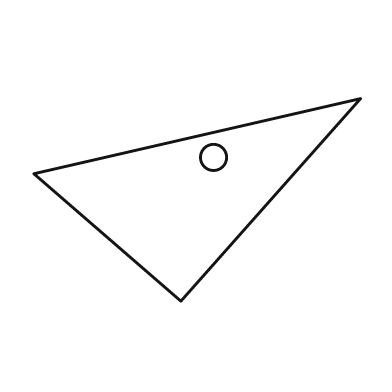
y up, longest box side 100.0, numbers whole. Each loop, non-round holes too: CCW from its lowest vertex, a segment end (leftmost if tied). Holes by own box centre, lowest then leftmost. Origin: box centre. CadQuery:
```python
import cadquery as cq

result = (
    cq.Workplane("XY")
    .moveTo(-5.0, -31.0)
    .lineTo(50.0, 31.0)
    .lineTo(-50.0, 8.0)
    .close()
    .moveTo(5.0, 13.0)
    .circle(4.0)
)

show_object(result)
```